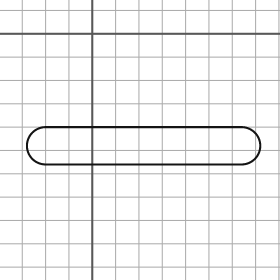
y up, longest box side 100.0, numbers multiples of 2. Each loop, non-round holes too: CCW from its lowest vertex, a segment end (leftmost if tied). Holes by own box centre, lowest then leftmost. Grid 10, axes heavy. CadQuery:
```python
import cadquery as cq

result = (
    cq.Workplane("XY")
    .moveTo(-20.0, -56.0)
    .lineTo(64.0, -56.0)
    .threePointArc((72.0, -48.0), (64.0, -40.0))
    .lineTo(-20.0, -40.0)
    .threePointArc((-28.0, -48.0), (-20.0, -56.0))
    .close()
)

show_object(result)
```